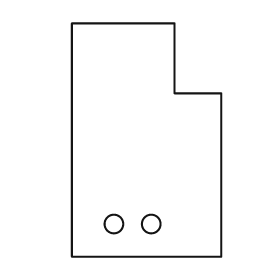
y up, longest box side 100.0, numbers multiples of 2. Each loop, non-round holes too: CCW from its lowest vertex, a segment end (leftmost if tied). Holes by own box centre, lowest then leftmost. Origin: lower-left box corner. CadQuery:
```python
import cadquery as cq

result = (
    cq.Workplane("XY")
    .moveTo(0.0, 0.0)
    .lineTo(64.0, 0.0)
    .lineTo(64.0, 70.0)
    .lineTo(44.0, 70.0)
    .lineTo(44.0, 100.0)
    .lineTo(0.0, 100.0)
    .close()
    .moveTo(18.0, 14.0)
    .circle(4.0)
    .moveTo(34.0, 14.0)
    .circle(4.0)
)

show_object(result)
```